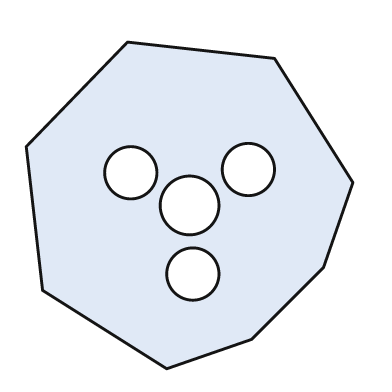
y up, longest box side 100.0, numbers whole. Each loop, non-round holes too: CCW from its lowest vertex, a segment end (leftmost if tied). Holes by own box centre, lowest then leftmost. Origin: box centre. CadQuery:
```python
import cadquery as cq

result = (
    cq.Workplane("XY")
    .moveTo(-7.0, -50.0)
    .lineTo(19.0, -41.0)
    .lineTo(41.0, -19.0)
    .lineTo(50.0, 7.0)
    .lineTo(26.0, 45.0)
    .lineTo(-19.0, 50.0)
    .lineTo(-50.0, 18.0)
    .lineTo(-45.0, -26.0)
    .close()
    .moveTo(1.0, -21.0)
    .circle(8.0)
    .moveTo(0.0, 0.0)
    .circle(9.0)
    .moveTo(-18.0, 10.0)
    .circle(8.0)
    .moveTo(18.0, 11.0)
    .circle(8.0)
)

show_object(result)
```